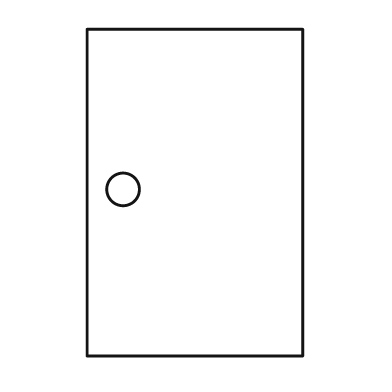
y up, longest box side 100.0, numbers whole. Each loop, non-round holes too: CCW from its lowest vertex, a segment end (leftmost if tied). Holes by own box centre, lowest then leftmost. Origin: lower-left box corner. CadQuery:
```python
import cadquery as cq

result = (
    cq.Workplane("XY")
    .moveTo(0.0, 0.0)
    .lineTo(66.0, 0.0)
    .lineTo(66.0, 100.0)
    .lineTo(0.0, 100.0)
    .close()
    .moveTo(11.0, 51.0)
    .circle(5.0)
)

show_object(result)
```